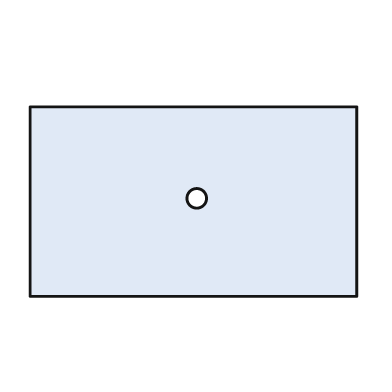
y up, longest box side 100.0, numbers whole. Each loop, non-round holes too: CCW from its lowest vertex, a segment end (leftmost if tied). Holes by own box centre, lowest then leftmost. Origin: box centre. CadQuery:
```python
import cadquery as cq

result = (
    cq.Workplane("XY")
    .moveTo(-50.0, -29.0)
    .lineTo(50.0, -29.0)
    .lineTo(50.0, 29.0)
    .lineTo(-50.0, 29.0)
    .close()
    .moveTo(1.0, 1.0)
    .circle(3.0)
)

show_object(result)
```